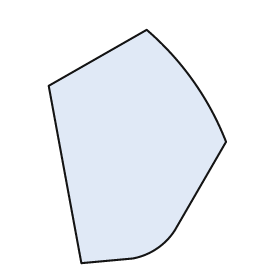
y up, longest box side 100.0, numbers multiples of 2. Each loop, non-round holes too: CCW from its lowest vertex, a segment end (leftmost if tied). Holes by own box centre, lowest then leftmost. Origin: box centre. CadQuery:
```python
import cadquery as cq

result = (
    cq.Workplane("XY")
    .moveTo(-24.0, -50.0)
    .lineTo(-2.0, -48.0)
    .threePointArc((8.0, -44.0), (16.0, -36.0))
    .lineTo(38.0, 2.0)
    .threePointArc((24.0, 28.0), (4.0, 50.0))
    .lineTo(-38.0, 26.0)
    .close()
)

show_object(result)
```